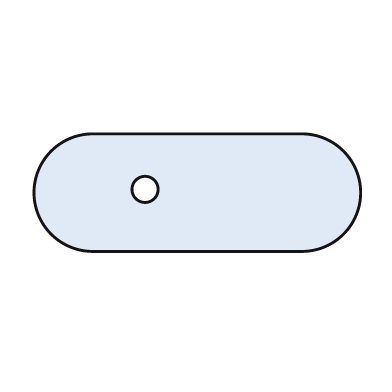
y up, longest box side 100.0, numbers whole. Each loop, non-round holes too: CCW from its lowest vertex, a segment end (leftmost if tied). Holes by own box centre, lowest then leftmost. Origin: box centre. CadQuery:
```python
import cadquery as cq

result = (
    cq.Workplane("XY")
    .moveTo(-32.0, -18.0)
    .lineTo(32.0, -18.0)
    .threePointArc((50.0, 0.0), (32.0, 18.0))
    .lineTo(-32.0, 18.0)
    .threePointArc((-50.0, 0.0), (-32.0, -18.0))
    .close()
    .moveTo(-16.0, 1.0)
    .circle(4.0)
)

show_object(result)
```